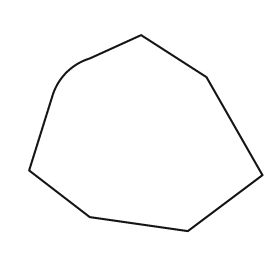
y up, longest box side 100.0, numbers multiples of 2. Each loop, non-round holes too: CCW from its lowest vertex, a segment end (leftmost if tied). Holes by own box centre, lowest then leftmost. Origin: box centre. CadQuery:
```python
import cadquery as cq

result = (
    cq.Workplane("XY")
    .moveTo(18.0, -42.0)
    .lineTo(50.0, -18.0)
    .lineTo(26.0, 24.0)
    .lineTo(-2.0, 42.0)
    .lineTo(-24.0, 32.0)
    .threePointArc((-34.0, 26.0), (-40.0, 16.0))
    .lineTo(-50.0, -16.0)
    .lineTo(-24.0, -36.0)
    .close()
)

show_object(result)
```